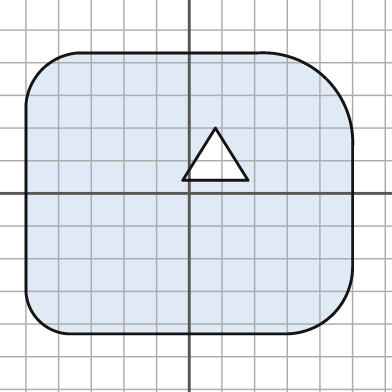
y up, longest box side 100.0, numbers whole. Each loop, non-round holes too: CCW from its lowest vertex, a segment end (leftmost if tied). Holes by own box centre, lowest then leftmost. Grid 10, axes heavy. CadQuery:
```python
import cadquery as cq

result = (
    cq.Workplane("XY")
    .moveTo(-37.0, -43.0)
    .lineTo(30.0, -43.0)
    .threePointArc((44.0, -37.0), (50.0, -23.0))
    .lineTo(50.0, 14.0)
    .threePointArc((42.0, 35.0), (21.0, 43.0))
    .lineTo(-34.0, 43.0)
    .threePointArc((-45.0, 38.0), (-50.0, 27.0))
    .lineTo(-50.0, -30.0)
    .threePointArc((-46.0, -39.0), (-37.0, -43.0))
    .close()
    .moveTo(-2.0, 4.0)
    .lineTo(18.0, 4.0)
    .lineTo(8.0, 20.0)
    .close()
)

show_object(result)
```